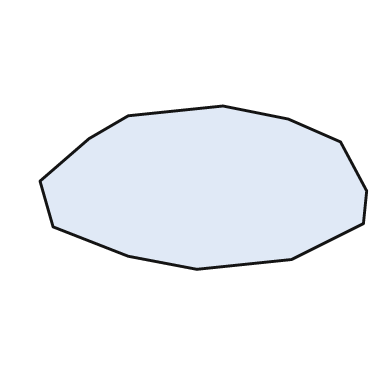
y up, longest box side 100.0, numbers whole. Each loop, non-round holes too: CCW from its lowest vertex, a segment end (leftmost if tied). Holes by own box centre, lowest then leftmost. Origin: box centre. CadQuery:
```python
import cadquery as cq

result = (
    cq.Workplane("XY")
    .moveTo(-2.0, -25.0)
    .lineTo(27.0, -22.0)
    .lineTo(49.0, -11.0)
    .lineTo(50.0, -1.0)
    .lineTo(42.0, 14.0)
    .lineTo(26.0, 21.0)
    .lineTo(6.0, 25.0)
    .lineTo(-23.0, 22.0)
    .lineTo(-35.0, 15.0)
    .lineTo(-50.0, 2.0)
    .lineTo(-46.0, -12.0)
    .lineTo(-23.0, -21.0)
    .close()
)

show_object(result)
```